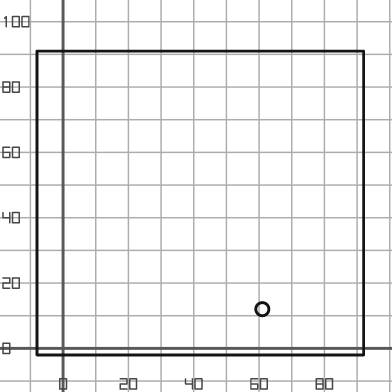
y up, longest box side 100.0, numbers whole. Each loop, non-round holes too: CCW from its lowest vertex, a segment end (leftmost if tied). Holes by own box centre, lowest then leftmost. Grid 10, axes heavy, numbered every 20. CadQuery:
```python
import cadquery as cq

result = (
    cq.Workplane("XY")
    .moveTo(-8.0, -2.0)
    .lineTo(92.0, -2.0)
    .lineTo(92.0, 91.0)
    .lineTo(-8.0, 91.0)
    .close()
    .moveTo(61.0, 12.0)
    .circle(2.0)
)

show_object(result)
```